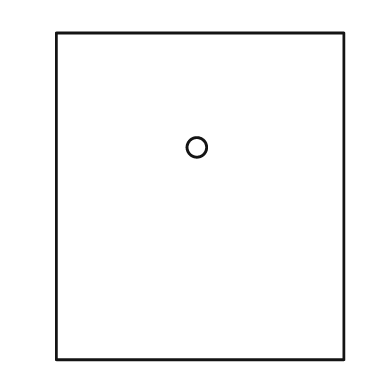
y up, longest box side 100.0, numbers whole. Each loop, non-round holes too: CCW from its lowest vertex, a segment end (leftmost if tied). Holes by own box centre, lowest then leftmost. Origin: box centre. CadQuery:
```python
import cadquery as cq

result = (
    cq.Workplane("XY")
    .moveTo(-44.0, -50.0)
    .lineTo(44.0, -50.0)
    .lineTo(44.0, 50.0)
    .lineTo(-44.0, 50.0)
    .close()
    .moveTo(-1.0, 15.0)
    .circle(3.0)
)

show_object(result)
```